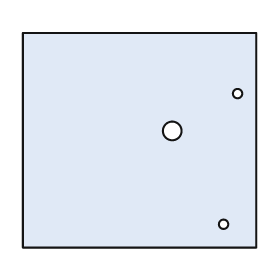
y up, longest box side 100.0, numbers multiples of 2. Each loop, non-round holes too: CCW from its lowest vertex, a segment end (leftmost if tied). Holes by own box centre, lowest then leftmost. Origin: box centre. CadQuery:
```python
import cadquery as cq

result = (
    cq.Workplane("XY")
    .moveTo(-50.0, -46.0)
    .lineTo(50.0, -46.0)
    .lineTo(50.0, 46.0)
    .lineTo(-50.0, 46.0)
    .close()
    .moveTo(36.0, -36.0)
    .circle(2.0)
    .moveTo(14.0, 4.0)
    .circle(4.0)
    .moveTo(42.0, 20.0)
    .circle(2.0)
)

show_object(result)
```